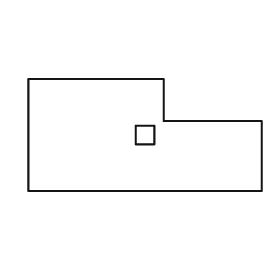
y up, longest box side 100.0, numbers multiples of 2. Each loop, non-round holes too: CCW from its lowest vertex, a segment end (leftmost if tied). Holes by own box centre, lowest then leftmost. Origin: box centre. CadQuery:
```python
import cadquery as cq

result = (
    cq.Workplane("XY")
    .moveTo(-50.0, -24.0)
    .lineTo(50.0, -24.0)
    .lineTo(50.0, 6.0)
    .lineTo(8.0, 6.0)
    .lineTo(8.0, 24.0)
    .lineTo(-50.0, 24.0)
    .close()
    .moveTo(-4.0, -4.0)
    .lineTo(4.0, -4.0)
    .lineTo(4.0, 4.0)
    .lineTo(-4.0, 4.0)
    .close()
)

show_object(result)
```